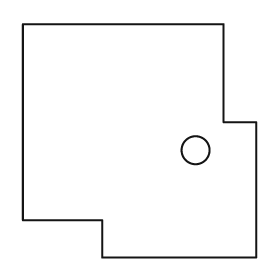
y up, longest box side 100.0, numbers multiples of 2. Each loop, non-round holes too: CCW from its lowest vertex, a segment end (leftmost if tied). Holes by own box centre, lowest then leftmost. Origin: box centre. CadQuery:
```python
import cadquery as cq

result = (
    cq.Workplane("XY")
    .moveTo(-16.0, -50.0)
    .lineTo(50.0, -50.0)
    .lineTo(50.0, 8.0)
    .lineTo(36.0, 8.0)
    .lineTo(36.0, 50.0)
    .lineTo(-50.0, 50.0)
    .lineTo(-50.0, -34.0)
    .lineTo(-16.0, -34.0)
    .close()
    .moveTo(24.0, -4.0)
    .circle(6.0)
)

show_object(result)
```